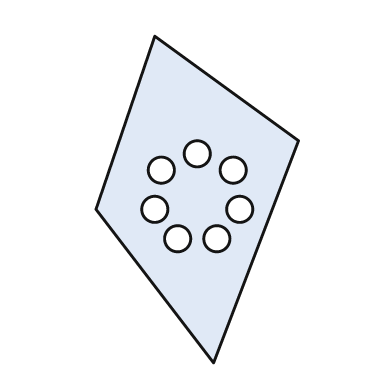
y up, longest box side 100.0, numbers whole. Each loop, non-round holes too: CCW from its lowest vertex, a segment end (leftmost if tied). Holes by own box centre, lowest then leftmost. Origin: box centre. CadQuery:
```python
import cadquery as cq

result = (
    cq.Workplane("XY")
    .moveTo(5.0, -50.0)
    .lineTo(31.0, 18.0)
    .lineTo(-13.0, 50.0)
    .lineTo(-31.0, -3.0)
    .close()
    .moveTo(-6.0, -12.0)
    .circle(4.0)
    .moveTo(6.0, -12.0)
    .circle(4.0)
    .moveTo(-13.0, -3.0)
    .circle(4.0)
    .moveTo(13.0, -3.0)
    .circle(4.0)
    .moveTo(-11.0, 9.0)
    .circle(4.0)
    .moveTo(11.0, 9.0)
    .circle(4.0)
    .moveTo(0.0, 14.0)
    .circle(4.0)
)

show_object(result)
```